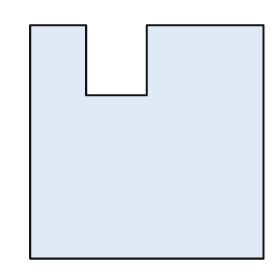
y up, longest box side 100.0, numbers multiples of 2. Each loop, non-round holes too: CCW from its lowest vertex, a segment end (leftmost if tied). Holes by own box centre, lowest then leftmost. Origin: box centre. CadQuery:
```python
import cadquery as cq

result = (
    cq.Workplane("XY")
    .moveTo(-50.0, -50.0)
    .lineTo(50.0, -50.0)
    .lineTo(50.0, 50.0)
    .lineTo(0.0, 50.0)
    .lineTo(0.0, 20.0)
    .lineTo(-26.0, 20.0)
    .lineTo(-26.0, 50.0)
    .lineTo(-50.0, 50.0)
    .close()
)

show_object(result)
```